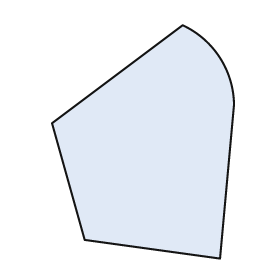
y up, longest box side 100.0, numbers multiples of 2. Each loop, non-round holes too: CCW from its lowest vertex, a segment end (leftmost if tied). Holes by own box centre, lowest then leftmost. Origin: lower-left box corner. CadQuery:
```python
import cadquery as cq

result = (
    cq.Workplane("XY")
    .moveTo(72.0, 0.0)
    .lineTo(78.0, 66.0)
    .threePointArc((72.0, 86.0), (56.0, 100.0))
    .lineTo(0.0, 58.0)
    .lineTo(14.0, 8.0)
    .close()
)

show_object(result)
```